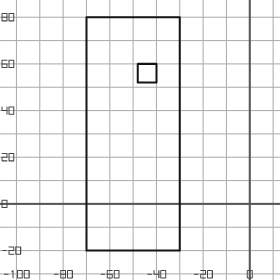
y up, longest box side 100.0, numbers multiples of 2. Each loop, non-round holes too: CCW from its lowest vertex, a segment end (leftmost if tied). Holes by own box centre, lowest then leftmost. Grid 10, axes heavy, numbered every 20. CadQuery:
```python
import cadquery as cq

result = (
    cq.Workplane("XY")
    .moveTo(-70.0, -20.0)
    .lineTo(-30.0, -20.0)
    .lineTo(-30.0, 80.0)
    .lineTo(-70.0, 80.0)
    .close()
    .moveTo(-48.0, 52.0)
    .lineTo(-40.0, 52.0)
    .lineTo(-40.0, 60.0)
    .lineTo(-48.0, 60.0)
    .close()
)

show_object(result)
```